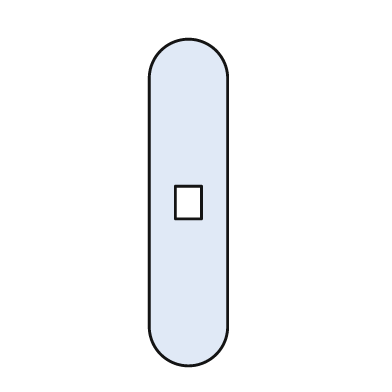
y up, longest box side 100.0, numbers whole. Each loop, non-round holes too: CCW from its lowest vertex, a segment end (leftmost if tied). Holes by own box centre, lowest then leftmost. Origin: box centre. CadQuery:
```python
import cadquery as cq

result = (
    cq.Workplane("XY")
    .moveTo(-12.0, -38.0)
    .threePointArc((0.0, -50.0), (12.0, -38.0))
    .lineTo(12.0, 38.0)
    .threePointArc((0.0, 50.0), (-12.0, 38.0))
    .close()
    .moveTo(-4.0, -5.0)
    .lineTo(4.0, -5.0)
    .lineTo(4.0, 5.0)
    .lineTo(-4.0, 5.0)
    .close()
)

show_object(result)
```